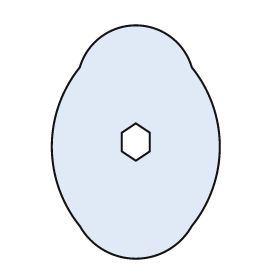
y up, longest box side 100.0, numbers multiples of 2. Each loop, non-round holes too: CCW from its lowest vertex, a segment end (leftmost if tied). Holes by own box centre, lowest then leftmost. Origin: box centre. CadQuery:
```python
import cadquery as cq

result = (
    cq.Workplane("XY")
    .moveTo(-24.0, -36.0)
    .threePointArc((0.0, -50.0), (24.0, -36.0))
    .threePointArc((36.0, -2.0), (24.0, 32.0))
    .threePointArc((0.0, 50.0), (-24.0, 32.0))
    .threePointArc((-36.0, -2.0), (-24.0, -36.0))
    .close()
    .moveTo(0.0, -8.0)
    .lineTo(6.0, -4.0)
    .lineTo(6.0, 4.0)
    .lineTo(0.0, 8.0)
    .lineTo(-6.0, 4.0)
    .lineTo(-6.0, -4.0)
    .close()
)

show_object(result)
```